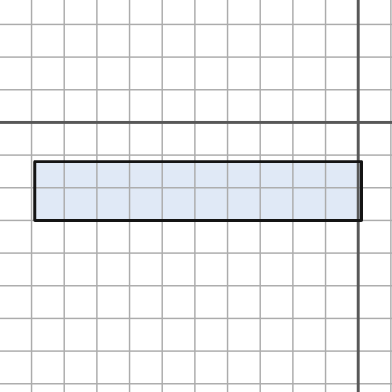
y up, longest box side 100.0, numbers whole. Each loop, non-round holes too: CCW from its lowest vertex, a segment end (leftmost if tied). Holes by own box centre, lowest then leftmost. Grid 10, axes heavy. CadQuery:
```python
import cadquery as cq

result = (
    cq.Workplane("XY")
    .moveTo(-99.0, -30.0)
    .lineTo(1.0, -30.0)
    .lineTo(1.0, -12.0)
    .lineTo(-99.0, -12.0)
    .close()
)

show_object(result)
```